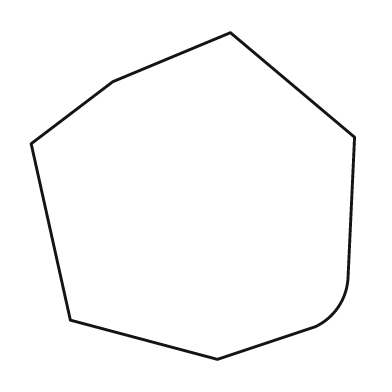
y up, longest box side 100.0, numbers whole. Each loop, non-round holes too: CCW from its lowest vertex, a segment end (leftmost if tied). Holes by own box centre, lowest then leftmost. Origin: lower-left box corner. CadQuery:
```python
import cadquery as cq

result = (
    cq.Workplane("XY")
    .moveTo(57.0, 0.0)
    .lineTo(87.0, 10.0)
    .threePointArc((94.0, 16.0), (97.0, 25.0))
    .lineTo(99.0, 68.0)
    .lineTo(61.0, 100.0)
    .lineTo(25.0, 85.0)
    .lineTo(0.0, 66.0)
    .lineTo(12.0, 12.0)
    .close()
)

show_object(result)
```